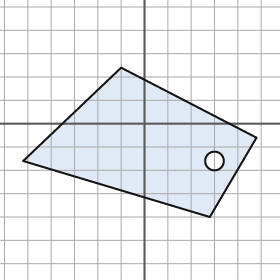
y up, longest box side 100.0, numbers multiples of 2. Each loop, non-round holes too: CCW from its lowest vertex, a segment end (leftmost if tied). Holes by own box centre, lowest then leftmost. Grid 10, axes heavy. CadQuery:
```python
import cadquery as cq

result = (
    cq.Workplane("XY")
    .moveTo(28.0, -40.0)
    .lineTo(48.0, -6.0)
    .lineTo(-10.0, 24.0)
    .lineTo(-52.0, -16.0)
    .close()
    .moveTo(30.0, -16.0)
    .circle(4.0)
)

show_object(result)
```